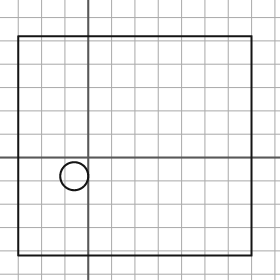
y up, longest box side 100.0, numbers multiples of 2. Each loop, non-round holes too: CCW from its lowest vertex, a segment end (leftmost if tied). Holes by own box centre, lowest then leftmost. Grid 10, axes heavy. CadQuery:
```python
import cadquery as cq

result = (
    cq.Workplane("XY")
    .moveTo(-30.0, -42.0)
    .lineTo(70.0, -42.0)
    .lineTo(70.0, 52.0)
    .lineTo(-30.0, 52.0)
    .close()
    .moveTo(-6.0, -8.0)
    .circle(6.0)
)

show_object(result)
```